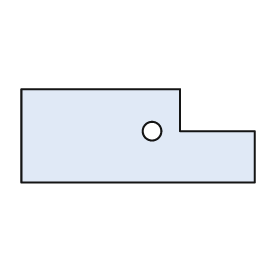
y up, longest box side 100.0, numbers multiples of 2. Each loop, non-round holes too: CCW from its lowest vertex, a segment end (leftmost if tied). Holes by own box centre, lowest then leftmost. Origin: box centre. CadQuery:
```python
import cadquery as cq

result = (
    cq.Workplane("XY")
    .moveTo(-50.0, -20.0)
    .lineTo(50.0, -20.0)
    .lineTo(50.0, 2.0)
    .lineTo(18.0, 2.0)
    .lineTo(18.0, 20.0)
    .lineTo(-50.0, 20.0)
    .close()
    .moveTo(6.0, 2.0)
    .circle(4.0)
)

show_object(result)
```